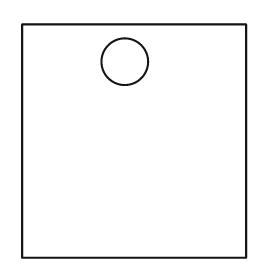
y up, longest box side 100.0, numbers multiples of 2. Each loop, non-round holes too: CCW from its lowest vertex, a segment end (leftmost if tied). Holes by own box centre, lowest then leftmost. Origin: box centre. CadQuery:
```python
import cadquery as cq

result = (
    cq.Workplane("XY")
    .moveTo(-48.0, -50.0)
    .lineTo(48.0, -50.0)
    .lineTo(48.0, 50.0)
    .lineTo(-48.0, 50.0)
    .close()
    .moveTo(-4.0, 34.0)
    .circle(10.0)
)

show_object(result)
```